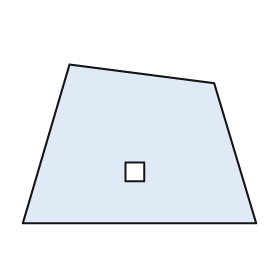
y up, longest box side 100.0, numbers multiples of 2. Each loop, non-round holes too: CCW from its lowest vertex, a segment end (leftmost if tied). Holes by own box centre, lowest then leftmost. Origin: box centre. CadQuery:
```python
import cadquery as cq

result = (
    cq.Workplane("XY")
    .moveTo(-50.0, -34.0)
    .lineTo(50.0, -34.0)
    .lineTo(32.0, 26.0)
    .lineTo(-30.0, 34.0)
    .close()
    .moveTo(-6.0, -16.0)
    .lineTo(2.0, -16.0)
    .lineTo(2.0, -8.0)
    .lineTo(-6.0, -8.0)
    .close()
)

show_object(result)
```